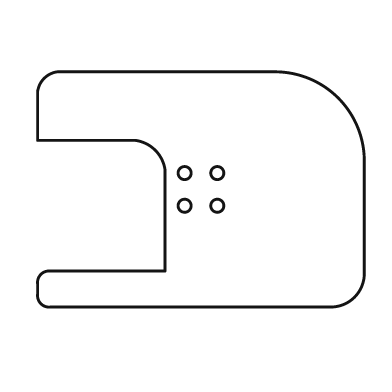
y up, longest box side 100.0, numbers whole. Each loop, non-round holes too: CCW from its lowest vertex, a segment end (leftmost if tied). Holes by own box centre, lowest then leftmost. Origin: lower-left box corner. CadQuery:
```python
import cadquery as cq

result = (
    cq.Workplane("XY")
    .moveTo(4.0, 0.0)
    .lineTo(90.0, 0.0)
    .threePointArc((97.0, 3.0), (100.0, 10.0))
    .lineTo(100.0, 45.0)
    .threePointArc((92.0, 64.0), (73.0, 72.0))
    .lineTo(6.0, 72.0)
    .threePointArc((2.0, 70.0), (0.0, 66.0))
    .lineTo(0.0, 51.0)
    .lineTo(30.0, 51.0)
    .threePointArc((36.0, 48.0), (39.0, 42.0))
    .lineTo(39.0, 11.0)
    .lineTo(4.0, 11.0)
    .threePointArc((1.0, 10.0), (0.0, 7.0))
    .lineTo(0.0, 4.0)
    .threePointArc((1.0, 1.0), (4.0, 0.0))
    .close()
    .moveTo(45.0, 31.0)
    .circle(2.0)
    .moveTo(55.0, 31.0)
    .circle(2.0)
    .moveTo(45.0, 41.0)
    .circle(2.0)
    .moveTo(55.0, 41.0)
    .circle(2.0)
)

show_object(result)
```